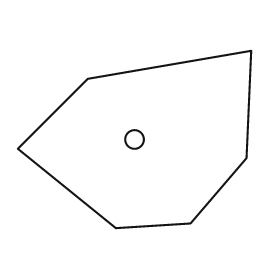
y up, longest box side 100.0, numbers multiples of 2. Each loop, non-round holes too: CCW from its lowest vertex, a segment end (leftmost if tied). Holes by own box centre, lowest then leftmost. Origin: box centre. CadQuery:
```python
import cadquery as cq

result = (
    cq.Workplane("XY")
    .moveTo(-8.0, -38.0)
    .lineTo(24.0, -36.0)
    .lineTo(48.0, -8.0)
    .lineTo(50.0, 38.0)
    .lineTo(-20.0, 26.0)
    .lineTo(-50.0, -4.0)
    .close()
    .moveTo(0.0, 0.0)
    .circle(4.0)
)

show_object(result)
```